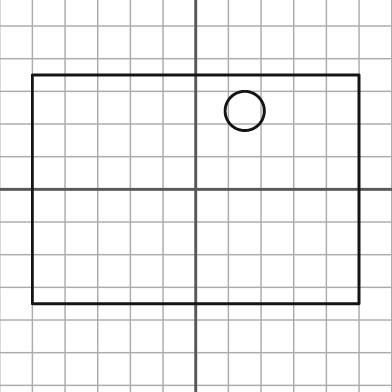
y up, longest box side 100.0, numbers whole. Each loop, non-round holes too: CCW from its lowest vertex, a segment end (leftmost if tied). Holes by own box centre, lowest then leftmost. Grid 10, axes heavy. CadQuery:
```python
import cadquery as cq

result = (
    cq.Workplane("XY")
    .moveTo(-50.0, -35.0)
    .lineTo(50.0, -35.0)
    .lineTo(50.0, 35.0)
    .lineTo(-50.0, 35.0)
    .close()
    .moveTo(15.0, 24.0)
    .circle(6.0)
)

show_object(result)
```